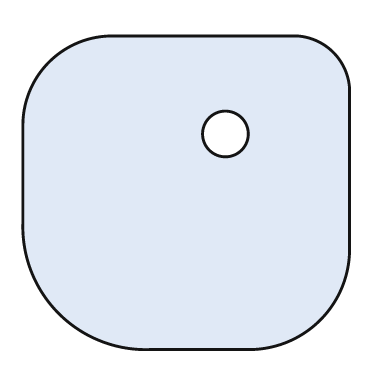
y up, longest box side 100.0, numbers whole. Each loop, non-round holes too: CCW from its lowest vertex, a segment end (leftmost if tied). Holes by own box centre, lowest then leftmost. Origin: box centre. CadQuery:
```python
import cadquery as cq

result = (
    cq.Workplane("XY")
    .moveTo(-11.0, -48.0)
    .lineTo(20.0, -48.0)
    .threePointArc((41.0, -39.0), (50.0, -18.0))
    .lineTo(50.0, 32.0)
    .threePointArc((45.0, 43.0), (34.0, 48.0))
    .lineTo(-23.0, 48.0)
    .threePointArc((-42.0, 40.0), (-50.0, 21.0))
    .lineTo(-50.0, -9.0)
    .threePointArc((-39.0, -37.0), (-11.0, -48.0))
    .close()
    .moveTo(12.0, 18.0)
    .circle(7.0)
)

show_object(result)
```